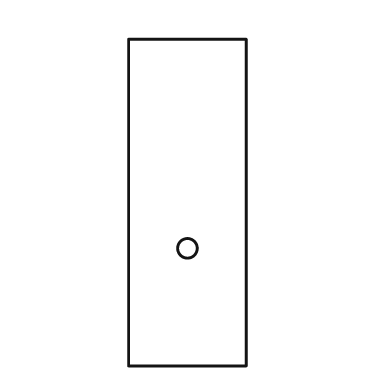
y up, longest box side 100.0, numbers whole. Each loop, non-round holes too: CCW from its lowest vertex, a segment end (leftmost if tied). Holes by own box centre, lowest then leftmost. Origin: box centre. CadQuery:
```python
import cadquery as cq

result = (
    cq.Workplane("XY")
    .moveTo(-18.0, -50.0)
    .lineTo(18.0, -50.0)
    .lineTo(18.0, 50.0)
    .lineTo(-18.0, 50.0)
    .close()
    .moveTo(0.0, -14.0)
    .circle(3.0)
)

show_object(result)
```